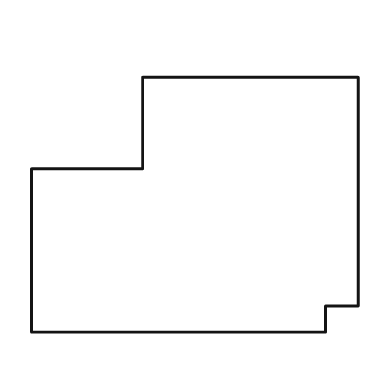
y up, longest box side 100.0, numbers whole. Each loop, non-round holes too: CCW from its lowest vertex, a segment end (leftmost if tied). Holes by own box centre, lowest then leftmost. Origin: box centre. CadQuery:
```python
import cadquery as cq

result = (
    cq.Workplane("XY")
    .moveTo(-50.0, -39.0)
    .lineTo(40.0, -39.0)
    .lineTo(40.0, -31.0)
    .lineTo(50.0, -31.0)
    .lineTo(50.0, 39.0)
    .lineTo(-16.0, 39.0)
    .lineTo(-16.0, 11.0)
    .lineTo(-50.0, 11.0)
    .close()
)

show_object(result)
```